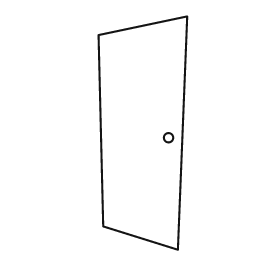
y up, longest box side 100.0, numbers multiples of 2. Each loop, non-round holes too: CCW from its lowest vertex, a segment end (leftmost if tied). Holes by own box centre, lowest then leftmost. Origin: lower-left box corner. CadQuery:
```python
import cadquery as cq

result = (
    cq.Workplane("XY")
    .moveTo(34.0, 0.0)
    .lineTo(38.0, 100.0)
    .lineTo(0.0, 92.0)
    .lineTo(2.0, 10.0)
    .close()
    .moveTo(30.0, 48.0)
    .circle(2.0)
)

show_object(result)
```